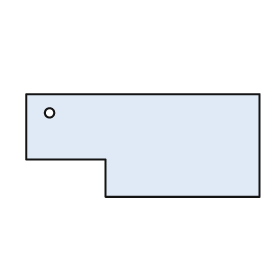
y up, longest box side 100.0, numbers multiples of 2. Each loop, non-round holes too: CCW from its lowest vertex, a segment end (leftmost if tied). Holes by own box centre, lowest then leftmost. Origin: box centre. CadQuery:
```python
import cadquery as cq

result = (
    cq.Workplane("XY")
    .moveTo(-16.0, -22.0)
    .lineTo(50.0, -22.0)
    .lineTo(50.0, 22.0)
    .lineTo(-50.0, 22.0)
    .lineTo(-50.0, -6.0)
    .lineTo(-16.0, -6.0)
    .close()
    .moveTo(-40.0, 14.0)
    .circle(2.0)
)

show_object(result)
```